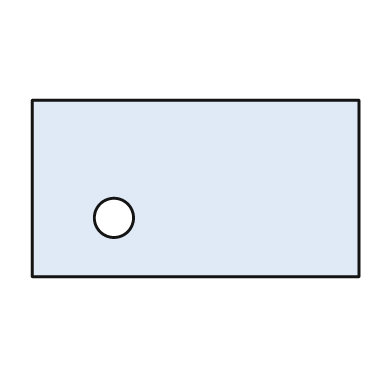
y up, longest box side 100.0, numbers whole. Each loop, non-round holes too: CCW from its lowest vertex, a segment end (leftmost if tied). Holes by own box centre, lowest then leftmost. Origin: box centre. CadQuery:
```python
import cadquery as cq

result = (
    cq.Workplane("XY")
    .moveTo(-50.0, -27.0)
    .lineTo(50.0, -27.0)
    .lineTo(50.0, 27.0)
    .lineTo(-50.0, 27.0)
    .close()
    .moveTo(-25.0, -9.0)
    .circle(6.0)
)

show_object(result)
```